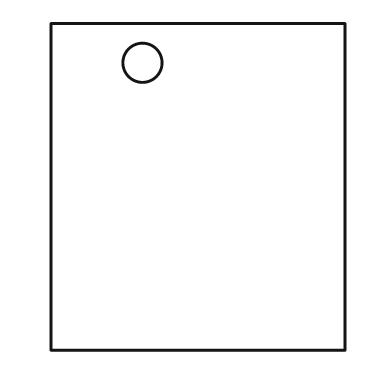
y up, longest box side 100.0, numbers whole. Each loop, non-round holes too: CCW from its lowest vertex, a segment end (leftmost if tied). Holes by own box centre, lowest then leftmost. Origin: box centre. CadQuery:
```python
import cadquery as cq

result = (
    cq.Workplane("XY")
    .moveTo(-45.0, -50.0)
    .lineTo(45.0, -50.0)
    .lineTo(45.0, 50.0)
    .lineTo(-45.0, 50.0)
    .close()
    .moveTo(-17.0, 38.0)
    .circle(6.0)
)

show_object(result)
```